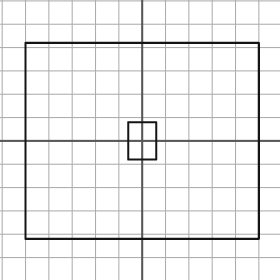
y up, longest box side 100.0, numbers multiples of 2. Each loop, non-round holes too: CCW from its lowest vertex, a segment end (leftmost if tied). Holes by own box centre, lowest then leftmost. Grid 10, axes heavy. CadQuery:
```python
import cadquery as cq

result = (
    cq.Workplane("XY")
    .moveTo(-50.0, -42.0)
    .lineTo(50.0, -42.0)
    .lineTo(50.0, 42.0)
    .lineTo(-50.0, 42.0)
    .close()
    .moveTo(-6.0, -8.0)
    .lineTo(6.0, -8.0)
    .lineTo(6.0, 8.0)
    .lineTo(-6.0, 8.0)
    .close()
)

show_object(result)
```